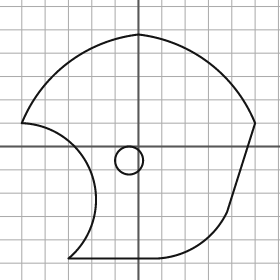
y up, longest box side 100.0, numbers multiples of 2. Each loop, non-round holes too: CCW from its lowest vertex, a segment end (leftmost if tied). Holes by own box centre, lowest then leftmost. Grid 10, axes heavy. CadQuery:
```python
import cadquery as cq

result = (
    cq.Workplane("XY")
    .moveTo(-30.0, -48.0)
    .lineTo(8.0, -48.0)
    .threePointArc((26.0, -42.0), (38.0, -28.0))
    .lineTo(50.0, 10.0)
    .threePointArc((30.0, 36.0), (0.0, 48.0))
    .threePointArc((-30.0, 36.0), (-50.0, 10.0))
    .threePointArc((-20.0, -12.0), (-30.0, -48.0))
    .close()
    .moveTo(-4.0, -6.0)
    .circle(6.0)
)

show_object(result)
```